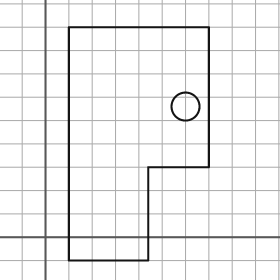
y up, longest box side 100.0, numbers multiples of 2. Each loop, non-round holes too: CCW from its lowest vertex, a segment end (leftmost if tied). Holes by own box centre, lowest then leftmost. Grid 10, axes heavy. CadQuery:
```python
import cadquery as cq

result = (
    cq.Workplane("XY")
    .moveTo(10.0, -10.0)
    .lineTo(44.0, -10.0)
    .lineTo(44.0, 30.0)
    .lineTo(70.0, 30.0)
    .lineTo(70.0, 90.0)
    .lineTo(10.0, 90.0)
    .close()
    .moveTo(60.0, 56.0)
    .circle(6.0)
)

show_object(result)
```